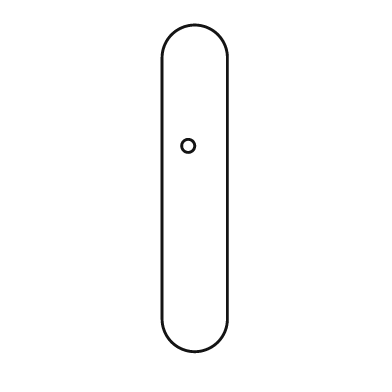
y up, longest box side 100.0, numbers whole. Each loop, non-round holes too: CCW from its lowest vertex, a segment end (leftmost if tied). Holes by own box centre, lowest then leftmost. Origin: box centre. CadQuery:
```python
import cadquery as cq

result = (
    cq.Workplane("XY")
    .moveTo(-10.0, -40.0)
    .threePointArc((0.0, -50.0), (10.0, -40.0))
    .lineTo(10.0, 40.0)
    .threePointArc((0.0, 50.0), (-10.0, 40.0))
    .close()
    .moveTo(-2.0, 13.0)
    .circle(2.0)
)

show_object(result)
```